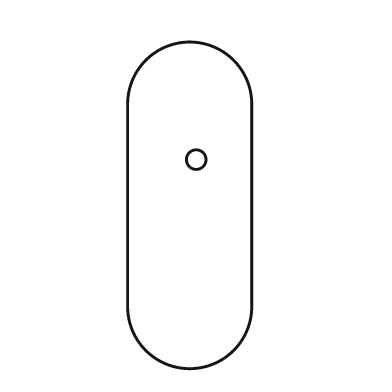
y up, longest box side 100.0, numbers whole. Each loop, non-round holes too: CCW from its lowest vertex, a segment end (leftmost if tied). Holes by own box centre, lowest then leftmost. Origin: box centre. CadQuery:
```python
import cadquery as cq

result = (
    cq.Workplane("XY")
    .moveTo(-19.0, -31.0)
    .threePointArc((0.0, -50.0), (19.0, -31.0))
    .lineTo(19.0, 31.0)
    .threePointArc((0.0, 50.0), (-19.0, 31.0))
    .close()
    .moveTo(2.0, 14.0)
    .circle(3.0)
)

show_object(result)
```